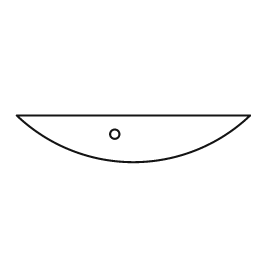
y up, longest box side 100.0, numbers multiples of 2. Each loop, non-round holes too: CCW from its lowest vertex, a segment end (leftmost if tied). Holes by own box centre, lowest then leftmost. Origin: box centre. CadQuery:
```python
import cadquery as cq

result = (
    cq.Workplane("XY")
    .moveTo(-50.0, 10.0)
    .threePointArc((0.0, -10.0), (50.0, 10.0))
    .close()
    .moveTo(-8.0, 2.0)
    .circle(2.0)
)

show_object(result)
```